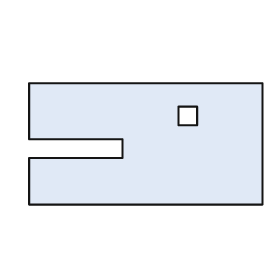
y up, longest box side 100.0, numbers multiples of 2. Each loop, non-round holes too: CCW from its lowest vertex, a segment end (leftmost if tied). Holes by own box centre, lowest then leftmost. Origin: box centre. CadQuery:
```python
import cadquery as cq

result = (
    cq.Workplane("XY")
    .moveTo(-50.0, -26.0)
    .lineTo(50.0, -26.0)
    .lineTo(50.0, 26.0)
    .lineTo(-50.0, 26.0)
    .lineTo(-50.0, 2.0)
    .lineTo(-10.0, 2.0)
    .lineTo(-10.0, -6.0)
    .lineTo(-50.0, -6.0)
    .close()
    .moveTo(14.0, 8.0)
    .lineTo(22.0, 8.0)
    .lineTo(22.0, 16.0)
    .lineTo(14.0, 16.0)
    .close()
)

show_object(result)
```